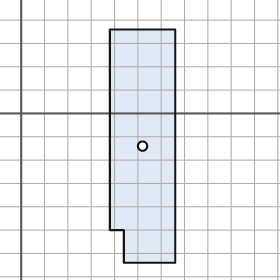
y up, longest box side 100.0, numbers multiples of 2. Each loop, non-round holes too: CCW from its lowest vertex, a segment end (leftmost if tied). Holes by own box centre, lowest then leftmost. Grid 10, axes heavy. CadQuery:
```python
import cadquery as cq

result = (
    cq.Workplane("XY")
    .moveTo(44.0, -64.0)
    .lineTo(66.0, -64.0)
    .lineTo(66.0, 36.0)
    .lineTo(38.0, 36.0)
    .lineTo(38.0, -50.0)
    .lineTo(44.0, -50.0)
    .close()
    .moveTo(52.0, -14.0)
    .circle(2.0)
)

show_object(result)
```